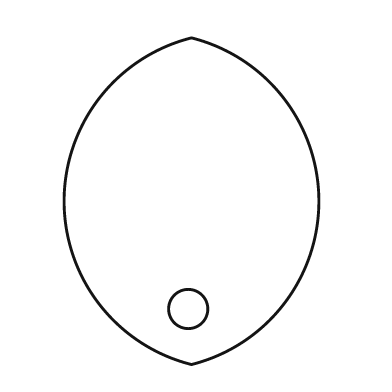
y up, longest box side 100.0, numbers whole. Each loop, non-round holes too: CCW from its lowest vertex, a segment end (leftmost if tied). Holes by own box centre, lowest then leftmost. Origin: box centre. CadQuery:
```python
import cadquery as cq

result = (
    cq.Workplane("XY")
    .moveTo(0.0, -50.0)
    .threePointArc((39.0, 0.0), (0.0, 50.0))
    .threePointArc((-39.0, 0.0), (0.0, -50.0))
    .close()
    .moveTo(-1.0, -33.0)
    .circle(6.0)
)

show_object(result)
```